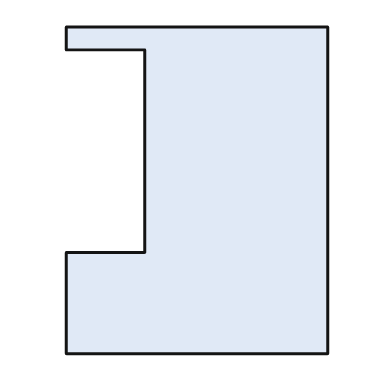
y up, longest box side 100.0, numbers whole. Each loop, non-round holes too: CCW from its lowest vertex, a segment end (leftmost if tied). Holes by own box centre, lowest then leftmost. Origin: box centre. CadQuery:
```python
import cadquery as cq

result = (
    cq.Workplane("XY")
    .moveTo(-40.0, -50.0)
    .lineTo(40.0, -50.0)
    .lineTo(40.0, 50.0)
    .lineTo(-40.0, 50.0)
    .lineTo(-40.0, 43.0)
    .lineTo(-16.0, 43.0)
    .lineTo(-16.0, -19.0)
    .lineTo(-40.0, -19.0)
    .close()
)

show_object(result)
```